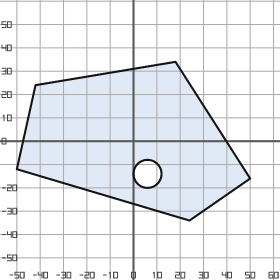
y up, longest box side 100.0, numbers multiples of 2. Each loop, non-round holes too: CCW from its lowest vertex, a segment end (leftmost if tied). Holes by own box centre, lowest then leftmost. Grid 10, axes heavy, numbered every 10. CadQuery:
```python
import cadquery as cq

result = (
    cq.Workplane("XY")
    .moveTo(24.0, -34.0)
    .lineTo(50.0, -16.0)
    .lineTo(18.0, 34.0)
    .lineTo(-42.0, 24.0)
    .lineTo(-50.0, -12.0)
    .close()
    .moveTo(6.0, -14.0)
    .circle(6.0)
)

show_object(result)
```